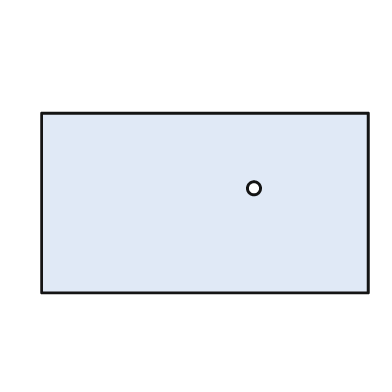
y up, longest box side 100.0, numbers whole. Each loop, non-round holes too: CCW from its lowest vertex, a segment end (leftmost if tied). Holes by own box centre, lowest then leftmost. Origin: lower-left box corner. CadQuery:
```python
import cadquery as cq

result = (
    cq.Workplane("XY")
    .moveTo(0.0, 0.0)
    .lineTo(100.0, 0.0)
    .lineTo(100.0, 55.0)
    .lineTo(0.0, 55.0)
    .close()
    .moveTo(65.0, 32.0)
    .circle(2.0)
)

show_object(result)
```